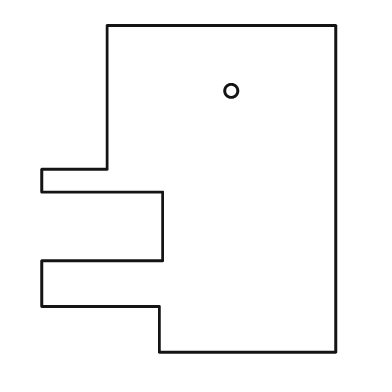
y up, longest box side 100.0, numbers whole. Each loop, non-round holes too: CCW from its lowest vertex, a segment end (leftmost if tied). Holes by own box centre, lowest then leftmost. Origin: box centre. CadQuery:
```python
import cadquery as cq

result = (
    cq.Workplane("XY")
    .moveTo(-9.0, -50.0)
    .lineTo(45.0, -50.0)
    .lineTo(45.0, 50.0)
    .lineTo(-25.0, 50.0)
    .lineTo(-25.0, 6.0)
    .lineTo(-45.0, 6.0)
    .lineTo(-45.0, -1.0)
    .lineTo(-8.0, -1.0)
    .lineTo(-8.0, -22.0)
    .lineTo(-45.0, -22.0)
    .lineTo(-45.0, -36.0)
    .lineTo(-9.0, -36.0)
    .close()
    .moveTo(13.0, 30.0)
    .circle(2.0)
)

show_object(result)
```